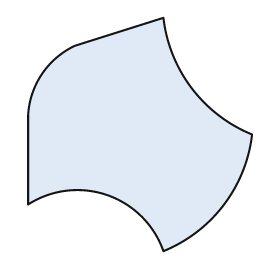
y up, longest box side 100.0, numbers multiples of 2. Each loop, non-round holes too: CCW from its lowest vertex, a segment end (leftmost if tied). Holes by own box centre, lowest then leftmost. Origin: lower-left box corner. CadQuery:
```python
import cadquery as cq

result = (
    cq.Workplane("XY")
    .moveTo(58.0, 0.0)
    .threePointArc((84.0, 20.0), (96.0, 50.0))
    .threePointArc((70.0, 70.0), (58.0, 100.0))
    .lineTo(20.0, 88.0)
    .threePointArc((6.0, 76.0), (0.0, 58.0))
    .lineTo(0.0, 20.0)
    .threePointArc((34.0, 24.0), (58.0, 0.0))
    .close()
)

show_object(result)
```